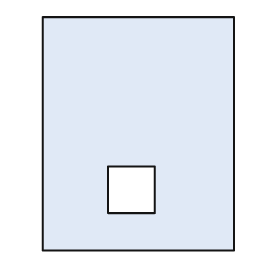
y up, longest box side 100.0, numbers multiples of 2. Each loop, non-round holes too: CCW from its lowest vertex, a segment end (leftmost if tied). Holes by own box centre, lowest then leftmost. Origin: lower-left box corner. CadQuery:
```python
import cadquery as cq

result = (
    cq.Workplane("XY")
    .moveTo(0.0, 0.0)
    .lineTo(82.0, 0.0)
    .lineTo(82.0, 100.0)
    .lineTo(0.0, 100.0)
    .close()
    .moveTo(28.0, 16.0)
    .lineTo(48.0, 16.0)
    .lineTo(48.0, 36.0)
    .lineTo(28.0, 36.0)
    .close()
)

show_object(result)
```